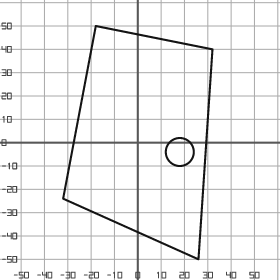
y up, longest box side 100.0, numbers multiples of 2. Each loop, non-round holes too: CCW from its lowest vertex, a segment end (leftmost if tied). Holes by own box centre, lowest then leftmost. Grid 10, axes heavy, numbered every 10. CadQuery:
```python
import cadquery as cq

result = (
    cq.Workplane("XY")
    .moveTo(26.0, -50.0)
    .lineTo(32.0, 40.0)
    .lineTo(-18.0, 50.0)
    .lineTo(-32.0, -24.0)
    .close()
    .moveTo(18.0, -4.0)
    .circle(6.0)
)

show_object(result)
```